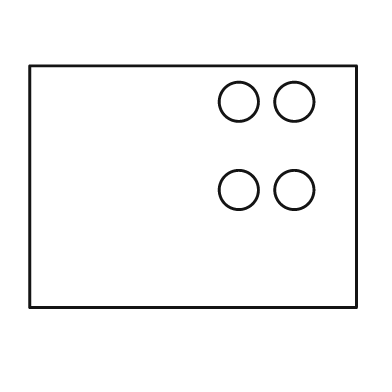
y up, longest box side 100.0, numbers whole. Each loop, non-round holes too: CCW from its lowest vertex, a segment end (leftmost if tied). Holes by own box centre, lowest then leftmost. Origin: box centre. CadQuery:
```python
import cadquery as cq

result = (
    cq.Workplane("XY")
    .moveTo(-50.0, -37.0)
    .lineTo(50.0, -37.0)
    .lineTo(50.0, 37.0)
    .lineTo(-50.0, 37.0)
    .close()
    .moveTo(14.0, -1.0)
    .circle(6.0)
    .moveTo(31.0, -1.0)
    .circle(6.0)
    .moveTo(14.0, 26.0)
    .circle(6.0)
    .moveTo(31.0, 26.0)
    .circle(6.0)
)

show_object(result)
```